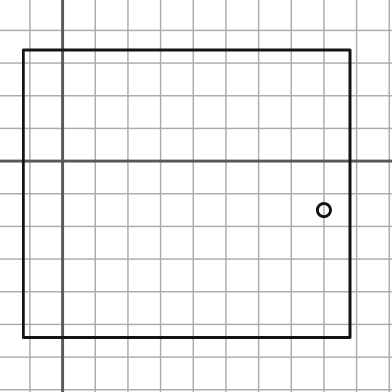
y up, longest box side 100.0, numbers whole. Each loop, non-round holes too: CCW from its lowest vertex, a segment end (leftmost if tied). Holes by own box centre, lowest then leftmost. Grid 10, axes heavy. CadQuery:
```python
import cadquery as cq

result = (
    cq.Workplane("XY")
    .moveTo(-12.0, -54.0)
    .lineTo(88.0, -54.0)
    .lineTo(88.0, 34.0)
    .lineTo(-12.0, 34.0)
    .close()
    .moveTo(80.0, -15.0)
    .circle(2.0)
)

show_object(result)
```